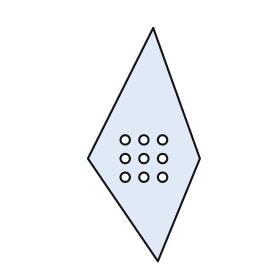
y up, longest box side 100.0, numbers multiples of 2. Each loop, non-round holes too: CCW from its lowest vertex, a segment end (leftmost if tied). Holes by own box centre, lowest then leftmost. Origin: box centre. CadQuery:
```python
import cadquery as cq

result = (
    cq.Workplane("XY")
    .moveTo(6.0, -50.0)
    .lineTo(24.0, -6.0)
    .lineTo(4.0, 50.0)
    .lineTo(-24.0, -6.0)
    .close()
    .moveTo(-8.0, -14.0)
    .circle(2.0)
    .moveTo(0.0, -14.0)
    .circle(2.0)
    .moveTo(8.0, -14.0)
    .circle(2.0)
    .moveTo(-8.0, -6.0)
    .circle(2.0)
    .moveTo(0.0, -6.0)
    .circle(2.0)
    .moveTo(8.0, -6.0)
    .circle(2.0)
    .moveTo(-8.0, 2.0)
    .circle(2.0)
    .moveTo(0.0, 2.0)
    .circle(2.0)
    .moveTo(8.0, 2.0)
    .circle(2.0)
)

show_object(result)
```